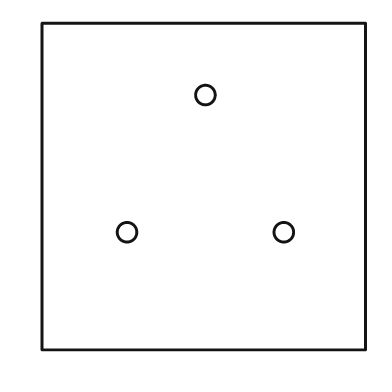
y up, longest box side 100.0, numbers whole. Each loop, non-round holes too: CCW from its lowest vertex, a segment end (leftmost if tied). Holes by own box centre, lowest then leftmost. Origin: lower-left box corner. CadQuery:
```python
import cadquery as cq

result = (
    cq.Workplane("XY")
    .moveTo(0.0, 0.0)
    .lineTo(99.0, 0.0)
    .lineTo(99.0, 100.0)
    .lineTo(0.0, 100.0)
    .close()
    .moveTo(26.0, 36.0)
    .circle(3.0)
    .moveTo(74.0, 36.0)
    .circle(3.0)
    .moveTo(50.0, 78.0)
    .circle(3.0)
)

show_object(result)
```